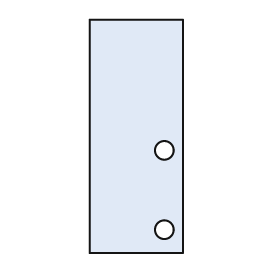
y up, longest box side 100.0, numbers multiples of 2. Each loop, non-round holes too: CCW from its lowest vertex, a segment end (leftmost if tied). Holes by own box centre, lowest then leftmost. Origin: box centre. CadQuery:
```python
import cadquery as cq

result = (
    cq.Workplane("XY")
    .moveTo(-20.0, -50.0)
    .lineTo(20.0, -50.0)
    .lineTo(20.0, 50.0)
    .lineTo(-20.0, 50.0)
    .close()
    .moveTo(12.0, -40.0)
    .circle(4.0)
    .moveTo(12.0, -6.0)
    .circle(4.0)
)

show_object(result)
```